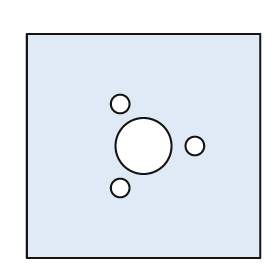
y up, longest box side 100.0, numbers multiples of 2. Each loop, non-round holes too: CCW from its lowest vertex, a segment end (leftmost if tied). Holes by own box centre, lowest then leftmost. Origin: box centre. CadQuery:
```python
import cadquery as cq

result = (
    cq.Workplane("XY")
    .moveTo(-50.0, -48.0)
    .lineTo(50.0, -48.0)
    .lineTo(50.0, 48.0)
    .lineTo(-50.0, 48.0)
    .close()
    .moveTo(-10.0, -18.0)
    .circle(4.0)
    .moveTo(0.0, 0.0)
    .circle(12.0)
    .moveTo(22.0, 0.0)
    .circle(4.0)
    .moveTo(-10.0, 18.0)
    .circle(4.0)
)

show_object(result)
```